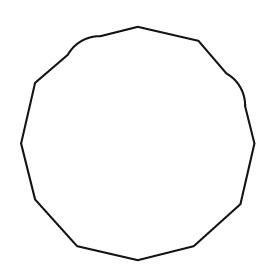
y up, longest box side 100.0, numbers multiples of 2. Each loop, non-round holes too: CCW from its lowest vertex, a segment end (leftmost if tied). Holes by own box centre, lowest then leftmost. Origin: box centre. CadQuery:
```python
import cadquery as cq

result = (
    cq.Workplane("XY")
    .moveTo(0.0, -50.0)
    .lineTo(24.0, -44.0)
    .lineTo(44.0, -26.0)
    .lineTo(50.0, 0.0)
    .lineTo(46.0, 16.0)
    .threePointArc((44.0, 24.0), (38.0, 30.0))
    .lineTo(26.0, 44.0)
    .lineTo(0.0, 50.0)
    .lineTo(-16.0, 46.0)
    .threePointArc((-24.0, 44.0), (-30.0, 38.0))
    .lineTo(-44.0, 26.0)
    .lineTo(-50.0, 0.0)
    .lineTo(-44.0, -24.0)
    .lineTo(-26.0, -44.0)
    .close()
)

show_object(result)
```